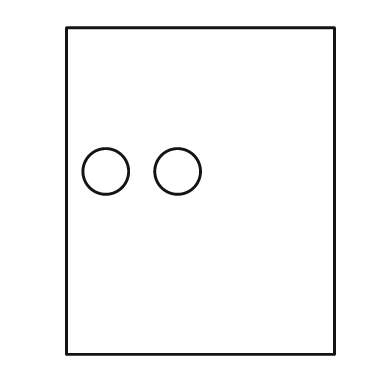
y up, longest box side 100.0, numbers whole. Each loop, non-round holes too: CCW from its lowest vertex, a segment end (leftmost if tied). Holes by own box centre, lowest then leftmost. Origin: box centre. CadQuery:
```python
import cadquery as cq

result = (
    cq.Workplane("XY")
    .moveTo(-41.0, -50.0)
    .lineTo(41.0, -50.0)
    .lineTo(41.0, 50.0)
    .lineTo(-41.0, 50.0)
    .close()
    .moveTo(-29.0, 6.0)
    .circle(7.0)
    .moveTo(-7.0, 6.0)
    .circle(7.0)
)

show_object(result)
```